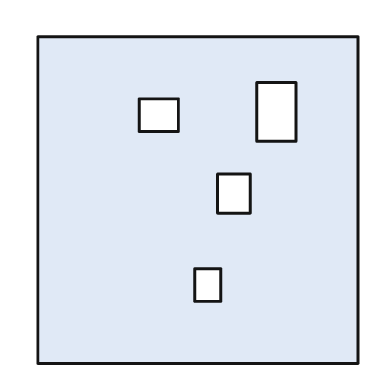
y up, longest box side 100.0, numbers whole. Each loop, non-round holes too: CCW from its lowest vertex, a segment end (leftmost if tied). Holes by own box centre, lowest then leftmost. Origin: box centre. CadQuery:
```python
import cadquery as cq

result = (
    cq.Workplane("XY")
    .moveTo(-49.0, -50.0)
    .lineTo(49.0, -50.0)
    .lineTo(49.0, 50.0)
    .lineTo(-49.0, 50.0)
    .close()
    .moveTo(-1.0, -31.0)
    .lineTo(7.0, -31.0)
    .lineTo(7.0, -21.0)
    .lineTo(-1.0, -21.0)
    .close()
    .moveTo(6.0, -4.0)
    .lineTo(16.0, -4.0)
    .lineTo(16.0, 8.0)
    .lineTo(6.0, 8.0)
    .close()
    .moveTo(-18.0, 21.0)
    .lineTo(-6.0, 21.0)
    .lineTo(-6.0, 31.0)
    .lineTo(-18.0, 31.0)
    .close()
    .moveTo(18.0, 18.0)
    .lineTo(30.0, 18.0)
    .lineTo(30.0, 36.0)
    .lineTo(18.0, 36.0)
    .close()
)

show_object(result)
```